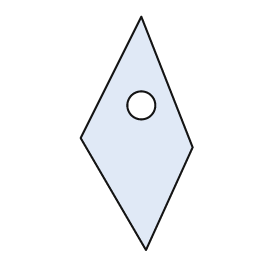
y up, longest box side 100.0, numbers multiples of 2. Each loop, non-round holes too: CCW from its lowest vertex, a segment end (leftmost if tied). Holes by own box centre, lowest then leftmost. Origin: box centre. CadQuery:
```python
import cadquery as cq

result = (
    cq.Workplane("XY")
    .moveTo(4.0, -50.0)
    .lineTo(24.0, -6.0)
    .lineTo(2.0, 50.0)
    .lineTo(-24.0, -2.0)
    .close()
    .moveTo(2.0, 12.0)
    .circle(6.0)
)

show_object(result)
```